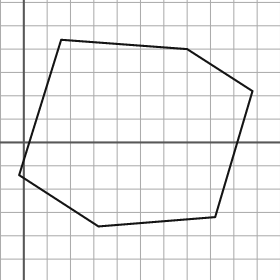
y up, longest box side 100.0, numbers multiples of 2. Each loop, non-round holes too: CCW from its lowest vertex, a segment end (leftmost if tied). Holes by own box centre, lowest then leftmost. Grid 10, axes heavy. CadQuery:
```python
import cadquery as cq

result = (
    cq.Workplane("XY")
    .moveTo(32.0, -36.0)
    .lineTo(82.0, -32.0)
    .lineTo(98.0, 22.0)
    .lineTo(70.0, 40.0)
    .lineTo(16.0, 44.0)
    .lineTo(-2.0, -14.0)
    .close()
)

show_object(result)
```